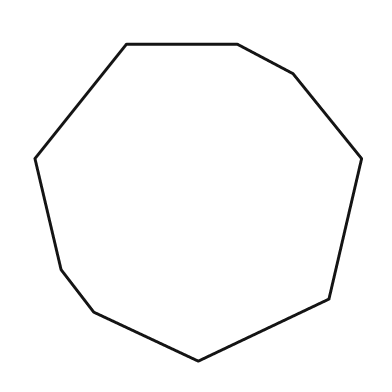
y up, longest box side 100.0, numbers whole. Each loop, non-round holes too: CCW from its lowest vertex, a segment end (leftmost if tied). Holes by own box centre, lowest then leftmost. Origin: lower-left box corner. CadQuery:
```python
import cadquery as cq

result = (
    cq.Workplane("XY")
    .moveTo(50.0, 0.0)
    .lineTo(90.0, 19.0)
    .lineTo(100.0, 62.0)
    .lineTo(79.0, 88.0)
    .lineTo(62.0, 97.0)
    .lineTo(28.0, 97.0)
    .lineTo(0.0, 62.0)
    .lineTo(8.0, 28.0)
    .lineTo(18.0, 15.0)
    .close()
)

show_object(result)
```